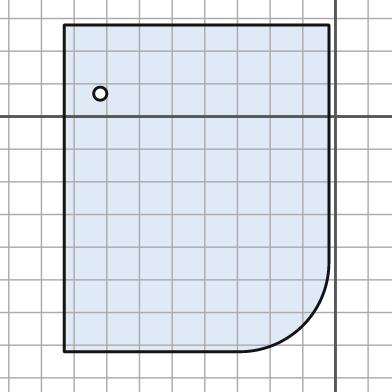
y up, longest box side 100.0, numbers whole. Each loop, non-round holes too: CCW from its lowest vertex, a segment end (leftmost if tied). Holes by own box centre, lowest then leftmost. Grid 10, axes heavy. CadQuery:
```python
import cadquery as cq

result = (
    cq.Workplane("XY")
    .moveTo(-83.0, -72.0)
    .lineTo(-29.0, -72.0)
    .threePointArc((-10.0, -64.0), (-2.0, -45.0))
    .lineTo(-2.0, 28.0)
    .lineTo(-83.0, 28.0)
    .close()
    .moveTo(-72.0, 7.0)
    .circle(2.0)
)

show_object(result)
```